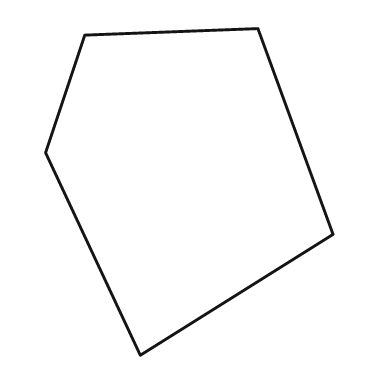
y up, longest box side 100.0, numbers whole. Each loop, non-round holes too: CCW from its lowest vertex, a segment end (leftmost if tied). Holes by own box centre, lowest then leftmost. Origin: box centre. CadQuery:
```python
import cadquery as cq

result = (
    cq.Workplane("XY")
    .moveTo(-15.0, -50.0)
    .lineTo(44.0, -13.0)
    .lineTo(21.0, 50.0)
    .lineTo(-32.0, 48.0)
    .lineTo(-44.0, 12.0)
    .close()
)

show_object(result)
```